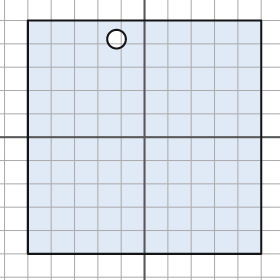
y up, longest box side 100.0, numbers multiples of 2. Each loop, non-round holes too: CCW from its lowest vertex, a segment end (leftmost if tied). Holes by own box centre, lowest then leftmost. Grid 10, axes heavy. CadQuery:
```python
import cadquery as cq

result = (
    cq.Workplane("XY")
    .moveTo(-50.0, -50.0)
    .lineTo(50.0, -50.0)
    .lineTo(50.0, 50.0)
    .lineTo(-50.0, 50.0)
    .close()
    .moveTo(-12.0, 42.0)
    .circle(4.0)
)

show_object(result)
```